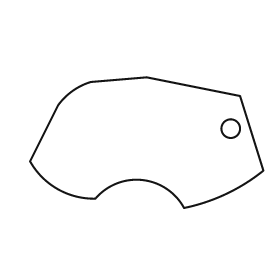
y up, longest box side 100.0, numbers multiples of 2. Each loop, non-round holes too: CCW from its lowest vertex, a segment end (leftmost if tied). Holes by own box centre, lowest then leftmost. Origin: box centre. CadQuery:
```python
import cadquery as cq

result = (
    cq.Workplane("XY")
    .moveTo(16.0, -28.0)
    .threePointArc((34.0, -22.0), (50.0, -12.0))
    .lineTo(40.0, 20.0)
    .lineTo(0.0, 28.0)
    .lineTo(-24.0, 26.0)
    .threePointArc((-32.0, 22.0), (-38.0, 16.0))
    .lineTo(-50.0, -8.0)
    .threePointArc((-38.0, -20.0), (-22.0, -24.0))
    .threePointArc((-2.0, -16.0), (16.0, -28.0))
    .close()
    .moveTo(36.0, 6.0)
    .circle(4.0)
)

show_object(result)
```